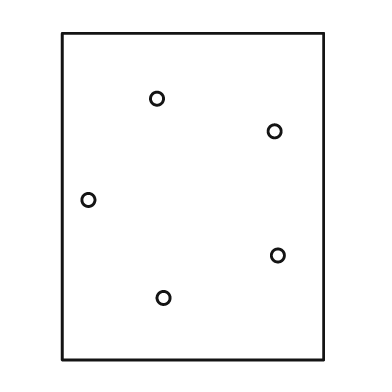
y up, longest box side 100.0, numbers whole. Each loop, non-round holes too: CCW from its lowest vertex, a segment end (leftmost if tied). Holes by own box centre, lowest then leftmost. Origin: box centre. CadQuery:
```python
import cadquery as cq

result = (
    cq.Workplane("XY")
    .moveTo(-40.0, -50.0)
    .lineTo(40.0, -50.0)
    .lineTo(40.0, 50.0)
    .lineTo(-40.0, 50.0)
    .close()
    .moveTo(-9.0, -31.0)
    .circle(2.0)
    .moveTo(26.0, -18.0)
    .circle(2.0)
    .moveTo(-32.0, -1.0)
    .circle(2.0)
    .moveTo(25.0, 20.0)
    .circle(2.0)
    .moveTo(-11.0, 30.0)
    .circle(2.0)
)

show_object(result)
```